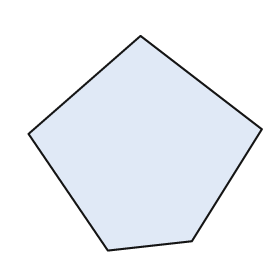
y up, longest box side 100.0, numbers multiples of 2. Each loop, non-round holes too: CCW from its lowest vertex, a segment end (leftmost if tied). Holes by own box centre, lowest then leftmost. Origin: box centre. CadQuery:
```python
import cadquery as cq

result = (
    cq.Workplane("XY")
    .moveTo(-16.0, -46.0)
    .lineTo(20.0, -42.0)
    .lineTo(50.0, 6.0)
    .lineTo(-2.0, 46.0)
    .lineTo(-50.0, 4.0)
    .close()
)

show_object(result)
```